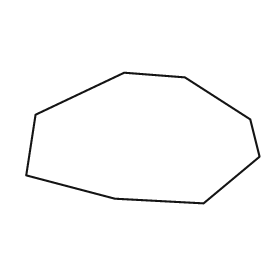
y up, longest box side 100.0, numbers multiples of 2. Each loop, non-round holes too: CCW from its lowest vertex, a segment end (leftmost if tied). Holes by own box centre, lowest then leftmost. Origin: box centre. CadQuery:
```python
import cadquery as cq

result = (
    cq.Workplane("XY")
    .moveTo(26.0, -28.0)
    .lineTo(50.0, -8.0)
    .lineTo(46.0, 8.0)
    .lineTo(18.0, 26.0)
    .lineTo(-8.0, 28.0)
    .lineTo(-46.0, 10.0)
    .lineTo(-50.0, -16.0)
    .lineTo(-12.0, -26.0)
    .close()
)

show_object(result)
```